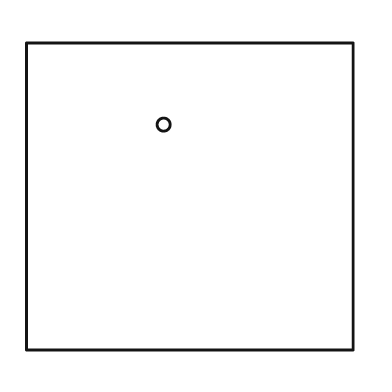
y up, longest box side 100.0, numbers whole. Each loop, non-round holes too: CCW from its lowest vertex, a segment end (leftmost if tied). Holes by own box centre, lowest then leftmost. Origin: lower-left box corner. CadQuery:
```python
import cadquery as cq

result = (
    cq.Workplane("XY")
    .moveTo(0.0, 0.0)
    .lineTo(100.0, 0.0)
    .lineTo(100.0, 94.0)
    .lineTo(0.0, 94.0)
    .close()
    .moveTo(42.0, 69.0)
    .circle(2.0)
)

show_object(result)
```